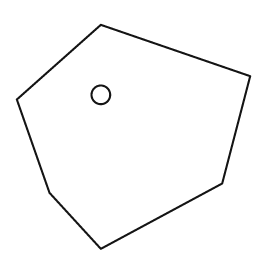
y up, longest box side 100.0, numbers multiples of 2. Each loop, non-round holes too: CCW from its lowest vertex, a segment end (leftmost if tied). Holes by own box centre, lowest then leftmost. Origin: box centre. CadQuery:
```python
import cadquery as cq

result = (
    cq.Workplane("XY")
    .moveTo(-14.0, -48.0)
    .lineTo(38.0, -20.0)
    .lineTo(50.0, 26.0)
    .lineTo(-14.0, 48.0)
    .lineTo(-50.0, 16.0)
    .lineTo(-36.0, -24.0)
    .close()
    .moveTo(-14.0, 18.0)
    .circle(4.0)
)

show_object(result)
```